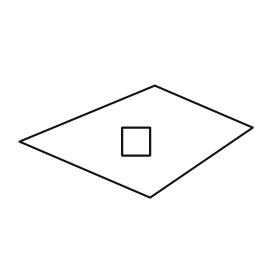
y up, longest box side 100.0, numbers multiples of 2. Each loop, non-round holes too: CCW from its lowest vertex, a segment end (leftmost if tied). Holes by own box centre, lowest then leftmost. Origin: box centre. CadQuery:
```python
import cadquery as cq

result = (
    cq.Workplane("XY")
    .moveTo(6.0, -24.0)
    .lineTo(50.0, 6.0)
    .lineTo(8.0, 24.0)
    .lineTo(-50.0, 0.0)
    .close()
    .moveTo(-6.0, -6.0)
    .lineTo(6.0, -6.0)
    .lineTo(6.0, 6.0)
    .lineTo(-6.0, 6.0)
    .close()
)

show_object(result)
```